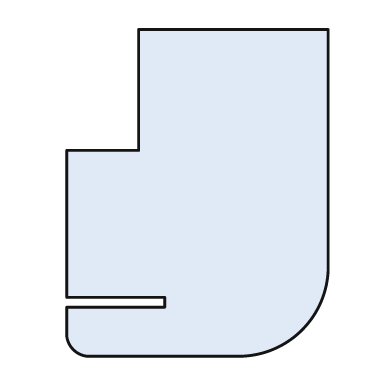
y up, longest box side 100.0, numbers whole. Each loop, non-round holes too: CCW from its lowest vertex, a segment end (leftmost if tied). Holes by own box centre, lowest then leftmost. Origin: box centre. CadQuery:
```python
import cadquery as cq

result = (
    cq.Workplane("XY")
    .moveTo(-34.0, -50.0)
    .lineTo(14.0, -50.0)
    .threePointArc((32.0, -42.0), (40.0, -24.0))
    .lineTo(40.0, 50.0)
    .lineTo(-18.0, 50.0)
    .lineTo(-18.0, 13.0)
    .lineTo(-40.0, 13.0)
    .lineTo(-40.0, -32.0)
    .lineTo(-10.0, -32.0)
    .lineTo(-10.0, -35.0)
    .lineTo(-40.0, -35.0)
    .lineTo(-40.0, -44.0)
    .threePointArc((-38.0, -48.0), (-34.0, -50.0))
    .close()
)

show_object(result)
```